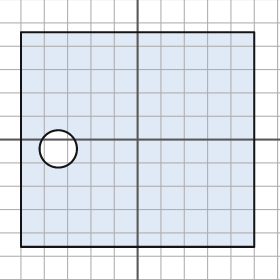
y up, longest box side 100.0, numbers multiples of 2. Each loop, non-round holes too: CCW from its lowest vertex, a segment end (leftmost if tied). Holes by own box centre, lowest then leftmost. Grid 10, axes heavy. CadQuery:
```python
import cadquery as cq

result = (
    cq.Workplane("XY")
    .moveTo(-50.0, -46.0)
    .lineTo(50.0, -46.0)
    .lineTo(50.0, 46.0)
    .lineTo(-50.0, 46.0)
    .close()
    .moveTo(-34.0, -4.0)
    .circle(8.0)
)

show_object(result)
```